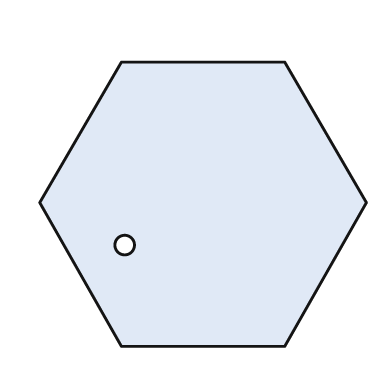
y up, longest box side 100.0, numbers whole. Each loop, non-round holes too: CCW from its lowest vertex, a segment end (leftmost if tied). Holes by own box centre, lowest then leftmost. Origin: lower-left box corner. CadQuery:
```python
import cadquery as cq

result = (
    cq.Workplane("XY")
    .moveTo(25.0, 0.0)
    .lineTo(75.0, 0.0)
    .lineTo(100.0, 44.0)
    .lineTo(75.0, 87.0)
    .lineTo(25.0, 87.0)
    .lineTo(0.0, 44.0)
    .close()
    .moveTo(26.0, 31.0)
    .circle(3.0)
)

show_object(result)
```